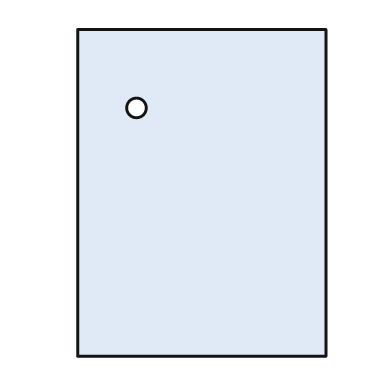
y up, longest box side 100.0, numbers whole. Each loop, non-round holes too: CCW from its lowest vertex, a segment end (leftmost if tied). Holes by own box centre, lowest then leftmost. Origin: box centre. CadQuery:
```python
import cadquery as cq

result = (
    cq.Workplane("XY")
    .moveTo(-38.0, -50.0)
    .lineTo(38.0, -50.0)
    .lineTo(38.0, 50.0)
    .lineTo(-38.0, 50.0)
    .close()
    .moveTo(-20.0, 26.0)
    .circle(3.0)
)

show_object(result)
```